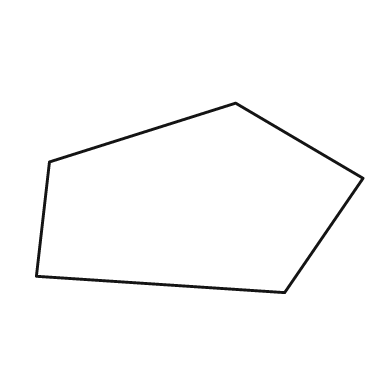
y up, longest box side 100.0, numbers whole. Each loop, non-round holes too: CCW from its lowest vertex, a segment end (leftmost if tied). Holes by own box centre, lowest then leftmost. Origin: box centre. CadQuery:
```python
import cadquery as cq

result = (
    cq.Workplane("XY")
    .moveTo(26.0, -29.0)
    .lineTo(50.0, 6.0)
    .lineTo(11.0, 29.0)
    .lineTo(-46.0, 11.0)
    .lineTo(-50.0, -24.0)
    .close()
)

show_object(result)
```